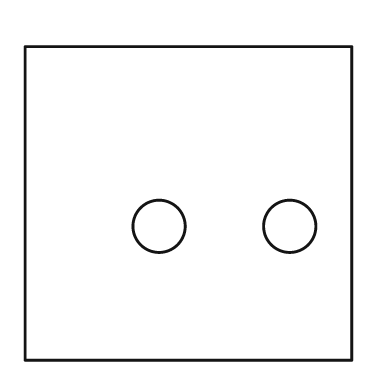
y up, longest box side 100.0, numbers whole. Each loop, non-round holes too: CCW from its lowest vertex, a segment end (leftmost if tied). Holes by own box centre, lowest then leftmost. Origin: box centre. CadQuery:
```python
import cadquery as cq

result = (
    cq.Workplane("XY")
    .moveTo(-50.0, -48.0)
    .lineTo(50.0, -48.0)
    .lineTo(50.0, 48.0)
    .lineTo(-50.0, 48.0)
    .close()
    .moveTo(-9.0, -7.0)
    .circle(8.0)
    .moveTo(31.0, -7.0)
    .circle(8.0)
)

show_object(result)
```